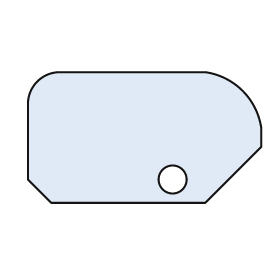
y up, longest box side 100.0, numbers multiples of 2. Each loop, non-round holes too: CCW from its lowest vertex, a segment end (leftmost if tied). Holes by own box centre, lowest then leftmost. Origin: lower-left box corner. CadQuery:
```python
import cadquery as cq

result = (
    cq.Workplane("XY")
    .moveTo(10.0, 0.0)
    .lineTo(76.0, 0.0)
    .lineTo(100.0, 24.0)
    .lineTo(100.0, 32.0)
    .threePointArc((92.0, 48.0), (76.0, 56.0))
    .lineTo(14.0, 56.0)
    .threePointArc((4.0, 52.0), (0.0, 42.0))
    .lineTo(0.0, 10.0)
    .close()
    .moveTo(62.0, 10.0)
    .circle(6.0)
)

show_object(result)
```